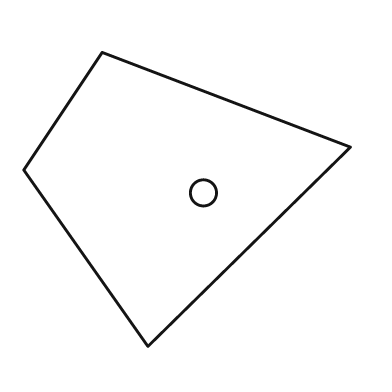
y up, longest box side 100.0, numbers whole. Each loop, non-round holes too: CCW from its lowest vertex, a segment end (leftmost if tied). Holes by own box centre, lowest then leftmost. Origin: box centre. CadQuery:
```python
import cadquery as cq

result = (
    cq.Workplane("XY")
    .moveTo(-12.0, -45.0)
    .lineTo(50.0, 16.0)
    .lineTo(-26.0, 45.0)
    .lineTo(-50.0, 9.0)
    .close()
    .moveTo(5.0, 2.0)
    .circle(4.0)
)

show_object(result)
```